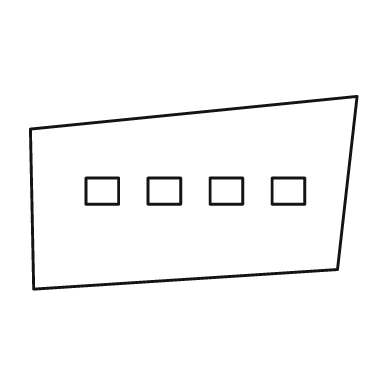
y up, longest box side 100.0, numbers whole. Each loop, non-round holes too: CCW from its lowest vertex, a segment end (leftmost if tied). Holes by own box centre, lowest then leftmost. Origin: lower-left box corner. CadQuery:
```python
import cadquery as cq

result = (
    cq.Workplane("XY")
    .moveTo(1.0, 0.0)
    .lineTo(94.0, 6.0)
    .lineTo(100.0, 59.0)
    .lineTo(0.0, 49.0)
    .close()
    .moveTo(17.0, 26.0)
    .lineTo(27.0, 26.0)
    .lineTo(27.0, 34.0)
    .lineTo(17.0, 34.0)
    .close()
    .moveTo(36.0, 26.0)
    .lineTo(46.0, 26.0)
    .lineTo(46.0, 34.0)
    .lineTo(36.0, 34.0)
    .close()
    .moveTo(55.0, 26.0)
    .lineTo(65.0, 26.0)
    .lineTo(65.0, 34.0)
    .lineTo(55.0, 34.0)
    .close()
    .moveTo(74.0, 26.0)
    .lineTo(84.0, 26.0)
    .lineTo(84.0, 34.0)
    .lineTo(74.0, 34.0)
    .close()
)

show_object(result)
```